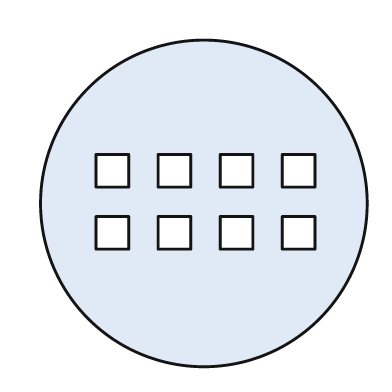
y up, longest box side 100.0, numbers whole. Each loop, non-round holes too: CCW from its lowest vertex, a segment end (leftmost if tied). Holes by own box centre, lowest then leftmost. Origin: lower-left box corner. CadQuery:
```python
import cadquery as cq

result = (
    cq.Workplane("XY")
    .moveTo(50.0, 50.0)
    .circle(50.0)
    .moveTo(17.0, 36.0)
    .lineTo(27.0, 36.0)
    .lineTo(27.0, 46.0)
    .lineTo(17.0, 46.0)
    .close()
    .moveTo(36.0, 36.0)
    .lineTo(46.0, 36.0)
    .lineTo(46.0, 46.0)
    .lineTo(36.0, 46.0)
    .close()
    .moveTo(55.0, 36.0)
    .lineTo(65.0, 36.0)
    .lineTo(65.0, 46.0)
    .lineTo(55.0, 46.0)
    .close()
    .moveTo(74.0, 36.0)
    .lineTo(84.0, 36.0)
    .lineTo(84.0, 46.0)
    .lineTo(74.0, 46.0)
    .close()
    .moveTo(17.0, 55.0)
    .lineTo(27.0, 55.0)
    .lineTo(27.0, 65.0)
    .lineTo(17.0, 65.0)
    .close()
    .moveTo(36.0, 55.0)
    .lineTo(46.0, 55.0)
    .lineTo(46.0, 65.0)
    .lineTo(36.0, 65.0)
    .close()
    .moveTo(55.0, 55.0)
    .lineTo(65.0, 55.0)
    .lineTo(65.0, 65.0)
    .lineTo(55.0, 65.0)
    .close()
    .moveTo(74.0, 55.0)
    .lineTo(84.0, 55.0)
    .lineTo(84.0, 65.0)
    .lineTo(74.0, 65.0)
    .close()
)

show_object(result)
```